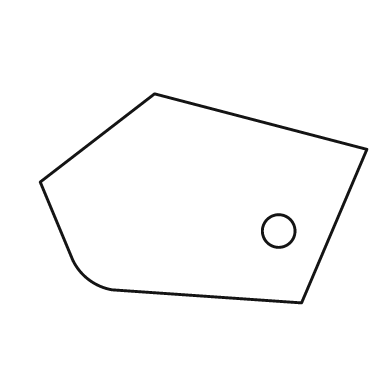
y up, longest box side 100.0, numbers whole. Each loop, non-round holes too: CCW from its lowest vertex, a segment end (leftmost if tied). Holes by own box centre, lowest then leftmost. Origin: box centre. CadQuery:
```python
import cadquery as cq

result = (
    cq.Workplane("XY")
    .moveTo(30.0, -32.0)
    .lineTo(50.0, 15.0)
    .lineTo(-15.0, 32.0)
    .lineTo(-50.0, 5.0)
    .lineTo(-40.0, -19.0)
    .threePointArc((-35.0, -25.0), (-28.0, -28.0))
    .close()
    .moveTo(23.0, -10.0)
    .circle(5.0)
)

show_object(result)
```